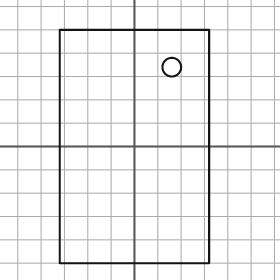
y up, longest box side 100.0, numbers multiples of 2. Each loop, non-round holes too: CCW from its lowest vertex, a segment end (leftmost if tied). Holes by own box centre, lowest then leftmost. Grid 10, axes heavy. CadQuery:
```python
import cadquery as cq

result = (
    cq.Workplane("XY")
    .moveTo(-32.0, -50.0)
    .lineTo(32.0, -50.0)
    .lineTo(32.0, 50.0)
    .lineTo(-32.0, 50.0)
    .close()
    .moveTo(16.0, 34.0)
    .circle(4.0)
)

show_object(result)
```